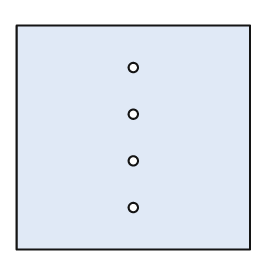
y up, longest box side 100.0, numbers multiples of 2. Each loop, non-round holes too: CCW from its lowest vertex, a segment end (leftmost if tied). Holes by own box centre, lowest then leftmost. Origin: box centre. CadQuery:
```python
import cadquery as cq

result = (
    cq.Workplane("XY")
    .moveTo(-50.0, -48.0)
    .lineTo(50.0, -48.0)
    .lineTo(50.0, 48.0)
    .lineTo(-50.0, 48.0)
    .close()
    .moveTo(0.0, -30.0)
    .circle(2.0)
    .moveTo(0.0, -10.0)
    .circle(2.0)
    .moveTo(0.0, 10.0)
    .circle(2.0)
    .moveTo(0.0, 30.0)
    .circle(2.0)
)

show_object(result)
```